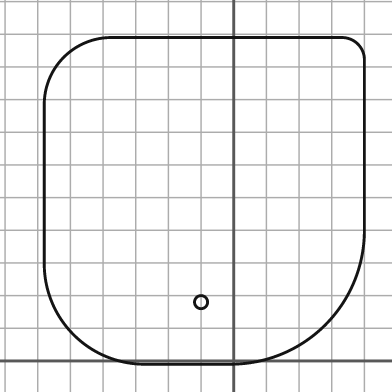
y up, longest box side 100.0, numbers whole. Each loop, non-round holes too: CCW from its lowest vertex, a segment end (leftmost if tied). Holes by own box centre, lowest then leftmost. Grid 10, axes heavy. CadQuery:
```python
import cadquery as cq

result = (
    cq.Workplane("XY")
    .moveTo(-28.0, -1.0)
    .lineTo(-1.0, -1.0)
    .threePointArc((28.0, 11.0), (40.0, 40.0))
    .lineTo(40.0, 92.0)
    .threePointArc((38.0, 97.0), (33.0, 99.0))
    .lineTo(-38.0, 99.0)
    .threePointArc((-52.0, 93.0), (-58.0, 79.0))
    .lineTo(-58.0, 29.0)
    .threePointArc((-49.0, 8.0), (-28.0, -1.0))
    .close()
    .moveTo(-10.0, 18.0)
    .circle(2.0)
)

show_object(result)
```